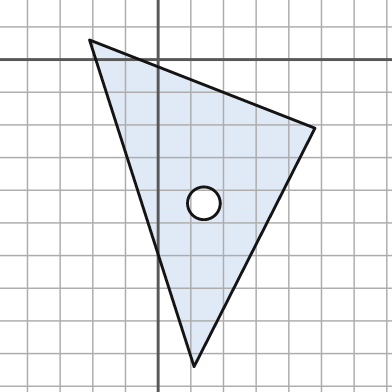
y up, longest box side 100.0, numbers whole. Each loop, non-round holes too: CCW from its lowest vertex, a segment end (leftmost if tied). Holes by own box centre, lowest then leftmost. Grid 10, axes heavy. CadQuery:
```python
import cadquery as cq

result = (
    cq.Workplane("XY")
    .moveTo(11.0, -94.0)
    .lineTo(48.0, -21.0)
    .lineTo(-21.0, 6.0)
    .close()
    .moveTo(14.0, -44.0)
    .circle(5.0)
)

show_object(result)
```